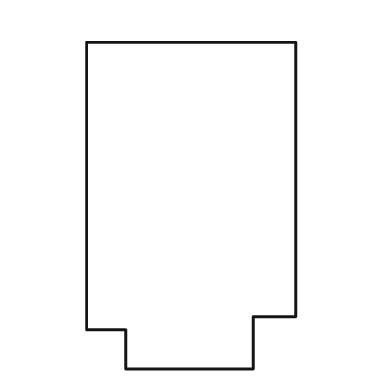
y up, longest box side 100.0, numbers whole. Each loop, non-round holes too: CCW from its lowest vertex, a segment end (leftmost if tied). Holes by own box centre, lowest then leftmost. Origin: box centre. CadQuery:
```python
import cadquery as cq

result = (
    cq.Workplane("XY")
    .moveTo(-20.0, -50.0)
    .lineTo(19.0, -50.0)
    .lineTo(19.0, -34.0)
    .lineTo(32.0, -34.0)
    .lineTo(32.0, 50.0)
    .lineTo(-32.0, 50.0)
    .lineTo(-32.0, -38.0)
    .lineTo(-20.0, -38.0)
    .close()
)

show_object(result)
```